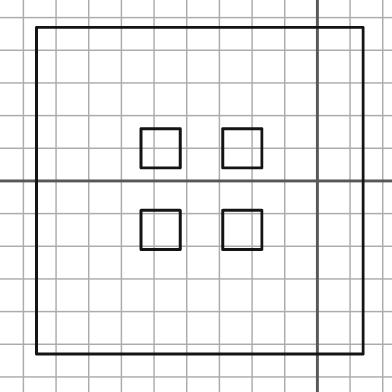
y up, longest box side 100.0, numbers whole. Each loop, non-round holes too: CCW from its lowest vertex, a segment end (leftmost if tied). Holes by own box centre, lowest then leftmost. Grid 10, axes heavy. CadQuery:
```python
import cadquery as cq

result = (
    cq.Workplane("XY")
    .moveTo(-86.0, -53.0)
    .lineTo(14.0, -53.0)
    .lineTo(14.0, 47.0)
    .lineTo(-86.0, 47.0)
    .close()
    .moveTo(-54.0, -21.0)
    .lineTo(-42.0, -21.0)
    .lineTo(-42.0, -9.0)
    .lineTo(-54.0, -9.0)
    .close()
    .moveTo(-29.0, -21.0)
    .lineTo(-17.0, -21.0)
    .lineTo(-17.0, -9.0)
    .lineTo(-29.0, -9.0)
    .close()
    .moveTo(-54.0, 4.0)
    .lineTo(-42.0, 4.0)
    .lineTo(-42.0, 16.0)
    .lineTo(-54.0, 16.0)
    .close()
    .moveTo(-29.0, 4.0)
    .lineTo(-17.0, 4.0)
    .lineTo(-17.0, 16.0)
    .lineTo(-29.0, 16.0)
    .close()
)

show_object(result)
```